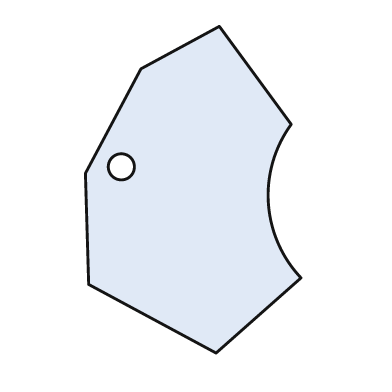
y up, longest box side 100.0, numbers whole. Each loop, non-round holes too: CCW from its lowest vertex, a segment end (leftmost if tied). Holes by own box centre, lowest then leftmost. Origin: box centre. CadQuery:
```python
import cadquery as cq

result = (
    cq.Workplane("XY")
    .moveTo(7.0, -50.0)
    .lineTo(33.0, -27.0)
    .threePointArc((23.0, -4.0), (30.0, 20.0))
    .lineTo(8.0, 50.0)
    .lineTo(-16.0, 37.0)
    .lineTo(-33.0, 5.0)
    .lineTo(-32.0, -29.0)
    .close()
    .moveTo(-22.0, 7.0)
    .circle(4.0)
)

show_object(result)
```